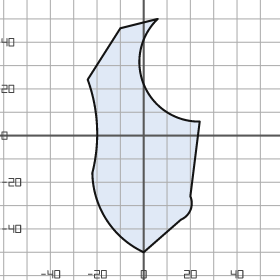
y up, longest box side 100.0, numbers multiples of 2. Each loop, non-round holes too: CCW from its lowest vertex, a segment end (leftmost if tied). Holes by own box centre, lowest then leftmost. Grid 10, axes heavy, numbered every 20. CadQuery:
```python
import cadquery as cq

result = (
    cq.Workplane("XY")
    .moveTo(0.0, -50.0)
    .lineTo(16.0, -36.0)
    .threePointArc((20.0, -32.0), (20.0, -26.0))
    .lineTo(24.0, 6.0)
    .threePointArc((0.0, 22.0), (6.0, 50.0))
    .lineTo(-10.0, 46.0)
    .lineTo(-24.0, 24.0)
    .threePointArc((-20.0, 4.0), (-22.0, -16.0))
    .threePointArc((-16.0, -36.0), (0.0, -50.0))
    .close()
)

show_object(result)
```